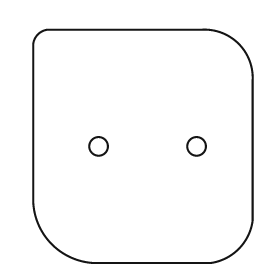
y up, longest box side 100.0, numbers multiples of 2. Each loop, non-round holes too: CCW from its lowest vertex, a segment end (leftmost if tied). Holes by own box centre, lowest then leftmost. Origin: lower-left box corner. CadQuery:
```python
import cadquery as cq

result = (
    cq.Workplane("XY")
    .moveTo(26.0, 0.0)
    .lineTo(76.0, 0.0)
    .threePointArc((88.0, 6.0), (94.0, 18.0))
    .lineTo(94.0, 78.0)
    .threePointArc((88.0, 94.0), (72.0, 100.0))
    .lineTo(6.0, 100.0)
    .threePointArc((2.0, 98.0), (0.0, 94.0))
    .lineTo(0.0, 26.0)
    .threePointArc((8.0, 8.0), (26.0, 0.0))
    .close()
    .moveTo(28.0, 50.0)
    .circle(4.0)
    .moveTo(70.0, 50.0)
    .circle(4.0)
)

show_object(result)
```